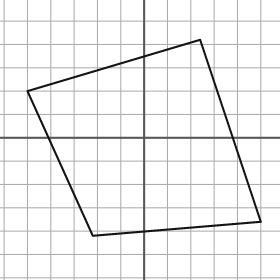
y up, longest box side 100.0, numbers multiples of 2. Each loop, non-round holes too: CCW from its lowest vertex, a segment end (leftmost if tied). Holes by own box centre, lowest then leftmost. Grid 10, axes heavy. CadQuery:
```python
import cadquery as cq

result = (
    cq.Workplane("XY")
    .moveTo(-22.0, -42.0)
    .lineTo(50.0, -36.0)
    .lineTo(24.0, 42.0)
    .lineTo(-50.0, 20.0)
    .close()
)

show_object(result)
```